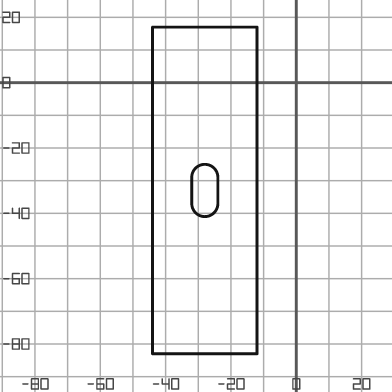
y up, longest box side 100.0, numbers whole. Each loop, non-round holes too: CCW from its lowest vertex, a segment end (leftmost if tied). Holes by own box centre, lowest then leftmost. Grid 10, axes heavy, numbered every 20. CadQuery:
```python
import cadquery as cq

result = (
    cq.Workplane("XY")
    .moveTo(-44.0, -83.0)
    .lineTo(-12.0, -83.0)
    .lineTo(-12.0, 17.0)
    .lineTo(-44.0, 17.0)
    .close()
    .moveTo(-32.0, -37.0)
    .threePointArc((-28.0, -41.0), (-24.0, -37.0))
    .lineTo(-24.0, -29.0)
    .threePointArc((-28.0, -25.0), (-32.0, -29.0))
    .close()
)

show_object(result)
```